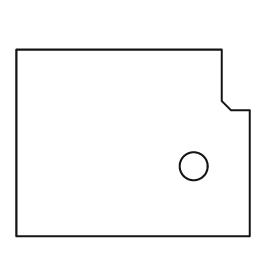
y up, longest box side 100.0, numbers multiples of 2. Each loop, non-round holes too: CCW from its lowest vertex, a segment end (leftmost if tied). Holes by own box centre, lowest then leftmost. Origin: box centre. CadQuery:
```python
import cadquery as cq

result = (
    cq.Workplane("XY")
    .moveTo(-50.0, -40.0)
    .lineTo(50.0, -40.0)
    .lineTo(50.0, 14.0)
    .lineTo(42.0, 14.0)
    .lineTo(38.0, 18.0)
    .lineTo(38.0, 40.0)
    .lineTo(-50.0, 40.0)
    .close()
    .moveTo(26.0, -10.0)
    .circle(6.0)
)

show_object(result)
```